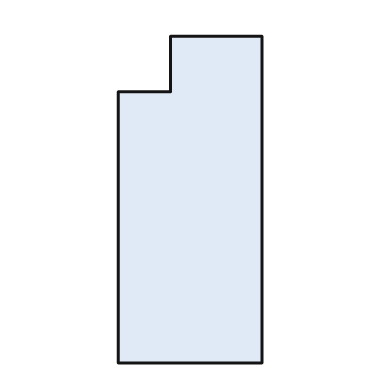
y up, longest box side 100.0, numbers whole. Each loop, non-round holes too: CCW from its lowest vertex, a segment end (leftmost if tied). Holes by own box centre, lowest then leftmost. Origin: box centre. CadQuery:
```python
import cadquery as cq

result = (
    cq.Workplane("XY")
    .moveTo(-22.0, -50.0)
    .lineTo(22.0, -50.0)
    .lineTo(22.0, 50.0)
    .lineTo(-6.0, 50.0)
    .lineTo(-6.0, 33.0)
    .lineTo(-22.0, 33.0)
    .close()
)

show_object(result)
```